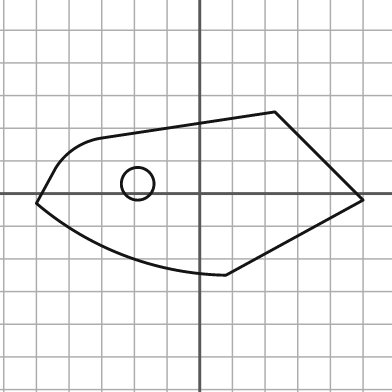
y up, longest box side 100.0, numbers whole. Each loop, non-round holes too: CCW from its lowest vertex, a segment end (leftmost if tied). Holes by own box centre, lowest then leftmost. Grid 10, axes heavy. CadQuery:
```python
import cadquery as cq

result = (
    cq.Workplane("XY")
    .moveTo(8.0, -25.0)
    .lineTo(50.0, -2.0)
    .lineTo(23.0, 25.0)
    .lineTo(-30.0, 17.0)
    .threePointArc((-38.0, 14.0), (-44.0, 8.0))
    .lineTo(-50.0, -3.0)
    .threePointArc((-23.0, -19.0), (8.0, -25.0))
    .close()
    .moveTo(-19.0, 3.0)
    .circle(5.0)
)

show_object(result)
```